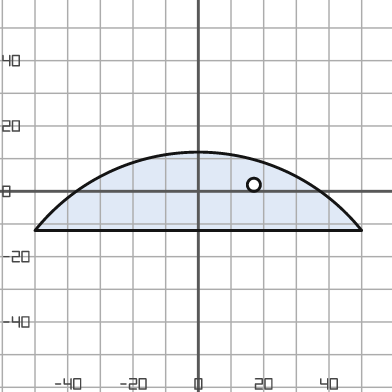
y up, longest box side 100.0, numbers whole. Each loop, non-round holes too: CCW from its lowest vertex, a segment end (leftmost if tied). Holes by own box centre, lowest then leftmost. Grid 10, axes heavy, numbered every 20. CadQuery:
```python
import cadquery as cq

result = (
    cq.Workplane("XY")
    .moveTo(-50.0, -12.0)
    .lineTo(50.0, -12.0)
    .threePointArc((0.0, 12.0), (-50.0, -12.0))
    .close()
    .moveTo(17.0, 2.0)
    .circle(2.0)
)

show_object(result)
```